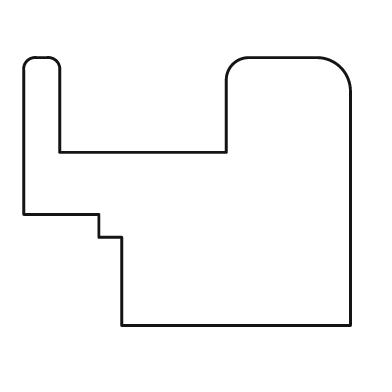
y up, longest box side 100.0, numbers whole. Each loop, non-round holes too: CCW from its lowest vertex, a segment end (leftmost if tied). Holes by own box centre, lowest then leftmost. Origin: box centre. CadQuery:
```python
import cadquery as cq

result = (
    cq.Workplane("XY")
    .moveTo(-20.0, -41.0)
    .lineTo(50.0, -41.0)
    .lineTo(50.0, 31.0)
    .threePointArc((47.0, 38.0), (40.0, 41.0))
    .lineTo(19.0, 41.0)
    .threePointArc((14.0, 39.0), (12.0, 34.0))
    .lineTo(12.0, 12.0)
    .lineTo(-39.0, 12.0)
    .lineTo(-39.0, 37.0)
    .threePointArc((-40.0, 40.0), (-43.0, 41.0))
    .lineTo(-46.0, 41.0)
    .threePointArc((-49.0, 40.0), (-50.0, 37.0))
    .lineTo(-50.0, -7.0)
    .lineTo(-27.0, -7.0)
    .lineTo(-27.0, -14.0)
    .lineTo(-20.0, -14.0)
    .close()
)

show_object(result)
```